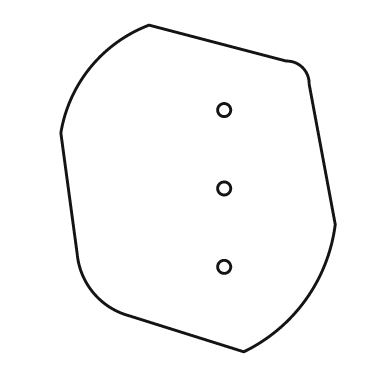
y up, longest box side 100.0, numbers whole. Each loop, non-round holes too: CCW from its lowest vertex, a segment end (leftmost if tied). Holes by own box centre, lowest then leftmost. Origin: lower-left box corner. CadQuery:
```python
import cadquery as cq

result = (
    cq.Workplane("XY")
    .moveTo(56.0, 0.0)
    .threePointArc((75.0, 16.0), (84.0, 39.0))
    .lineTo(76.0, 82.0)
    .threePointArc((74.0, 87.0), (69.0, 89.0))
    .lineTo(27.0, 100.0)
    .threePointArc((9.0, 87.0), (0.0, 67.0))
    .lineTo(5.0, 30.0)
    .threePointArc((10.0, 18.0), (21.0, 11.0))
    .close()
    .moveTo(50.0, 26.0)
    .circle(2.0)
    .moveTo(50.0, 50.0)
    .circle(2.0)
    .moveTo(50.0, 74.0)
    .circle(2.0)
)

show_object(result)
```